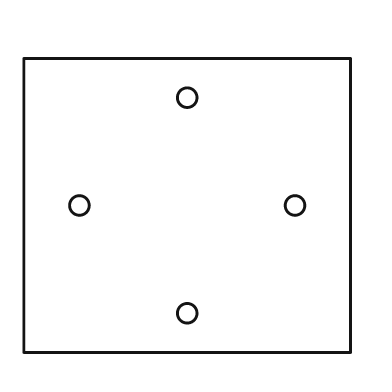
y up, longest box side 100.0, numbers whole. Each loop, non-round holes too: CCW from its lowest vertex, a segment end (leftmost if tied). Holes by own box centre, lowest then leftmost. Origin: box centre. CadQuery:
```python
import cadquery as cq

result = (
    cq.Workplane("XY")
    .moveTo(-50.0, -45.0)
    .lineTo(50.0, -45.0)
    .lineTo(50.0, 45.0)
    .lineTo(-50.0, 45.0)
    .close()
    .moveTo(0.0, -33.0)
    .circle(3.0)
    .moveTo(-33.0, 0.0)
    .circle(3.0)
    .moveTo(33.0, 0.0)
    .circle(3.0)
    .moveTo(0.0, 33.0)
    .circle(3.0)
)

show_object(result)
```